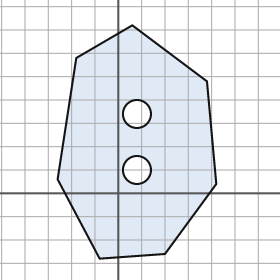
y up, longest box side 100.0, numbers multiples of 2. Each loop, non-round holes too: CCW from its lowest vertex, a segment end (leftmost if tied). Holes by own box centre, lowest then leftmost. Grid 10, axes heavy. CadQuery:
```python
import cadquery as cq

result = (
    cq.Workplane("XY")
    .moveTo(-8.0, -28.0)
    .lineTo(20.0, -26.0)
    .lineTo(42.0, 4.0)
    .lineTo(38.0, 48.0)
    .lineTo(6.0, 72.0)
    .lineTo(-18.0, 58.0)
    .lineTo(-26.0, 6.0)
    .close()
    .moveTo(8.0, 10.0)
    .circle(6.0)
    .moveTo(8.0, 34.0)
    .circle(6.0)
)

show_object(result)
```